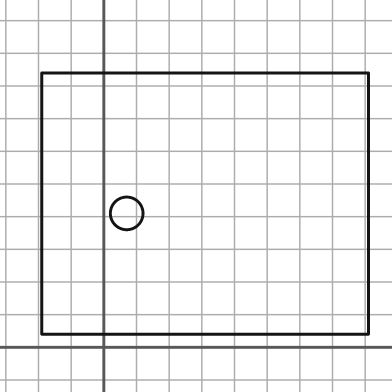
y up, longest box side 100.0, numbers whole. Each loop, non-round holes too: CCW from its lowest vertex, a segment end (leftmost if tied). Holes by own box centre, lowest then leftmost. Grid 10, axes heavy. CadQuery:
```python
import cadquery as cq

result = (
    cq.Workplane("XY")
    .moveTo(-19.0, 4.0)
    .lineTo(81.0, 4.0)
    .lineTo(81.0, 84.0)
    .lineTo(-19.0, 84.0)
    .close()
    .moveTo(7.0, 41.0)
    .circle(5.0)
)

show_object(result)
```